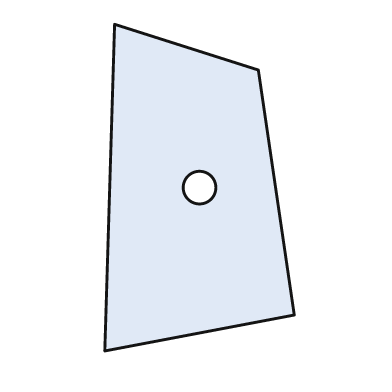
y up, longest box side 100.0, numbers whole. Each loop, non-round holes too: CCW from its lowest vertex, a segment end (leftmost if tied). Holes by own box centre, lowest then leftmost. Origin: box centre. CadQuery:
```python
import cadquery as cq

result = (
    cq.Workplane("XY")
    .moveTo(-29.0, -50.0)
    .lineTo(29.0, -39.0)
    .lineTo(18.0, 36.0)
    .lineTo(-26.0, 50.0)
    .close()
    .moveTo(0.0, 0.0)
    .circle(5.0)
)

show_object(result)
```